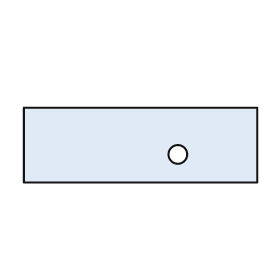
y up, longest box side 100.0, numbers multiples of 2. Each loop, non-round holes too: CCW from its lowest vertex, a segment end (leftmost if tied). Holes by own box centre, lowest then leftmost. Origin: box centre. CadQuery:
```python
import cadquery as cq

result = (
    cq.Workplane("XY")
    .moveTo(-50.0, -16.0)
    .lineTo(50.0, -16.0)
    .lineTo(50.0, 16.0)
    .lineTo(-50.0, 16.0)
    .close()
    .moveTo(16.0, -4.0)
    .circle(4.0)
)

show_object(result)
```